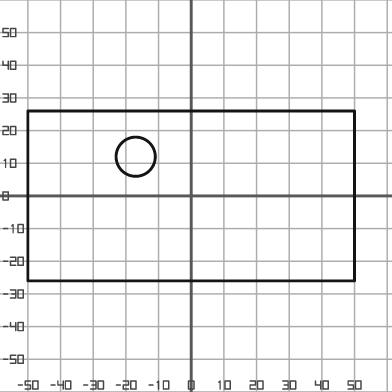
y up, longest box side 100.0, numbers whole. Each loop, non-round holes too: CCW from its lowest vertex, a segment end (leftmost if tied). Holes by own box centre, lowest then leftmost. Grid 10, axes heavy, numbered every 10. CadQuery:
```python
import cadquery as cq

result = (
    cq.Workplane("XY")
    .moveTo(-50.0, -26.0)
    .lineTo(50.0, -26.0)
    .lineTo(50.0, 26.0)
    .lineTo(-50.0, 26.0)
    .close()
    .moveTo(-17.0, 12.0)
    .circle(6.0)
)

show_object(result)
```